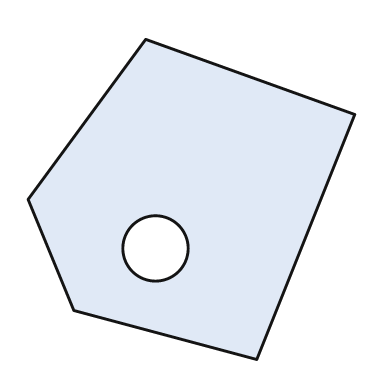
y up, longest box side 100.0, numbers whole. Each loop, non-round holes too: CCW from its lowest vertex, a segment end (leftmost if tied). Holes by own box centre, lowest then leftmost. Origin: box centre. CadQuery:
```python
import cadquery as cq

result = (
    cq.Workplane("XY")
    .moveTo(20.0, -49.0)
    .lineTo(50.0, 26.0)
    .lineTo(-14.0, 49.0)
    .lineTo(-50.0, 0.0)
    .lineTo(-36.0, -34.0)
    .close()
    .moveTo(-11.0, -15.0)
    .circle(10.0)
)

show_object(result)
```